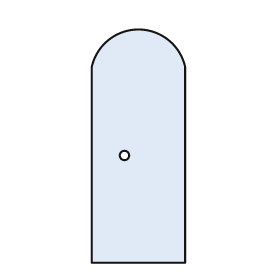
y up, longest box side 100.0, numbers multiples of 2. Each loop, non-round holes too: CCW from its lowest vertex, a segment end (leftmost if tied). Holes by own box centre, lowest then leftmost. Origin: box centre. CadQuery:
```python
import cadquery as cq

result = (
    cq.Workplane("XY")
    .moveTo(-20.0, -50.0)
    .lineTo(20.0, -50.0)
    .lineTo(20.0, 34.0)
    .threePointArc((0.0, 50.0), (-20.0, 34.0))
    .close()
    .moveTo(-6.0, -4.0)
    .circle(2.0)
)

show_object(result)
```